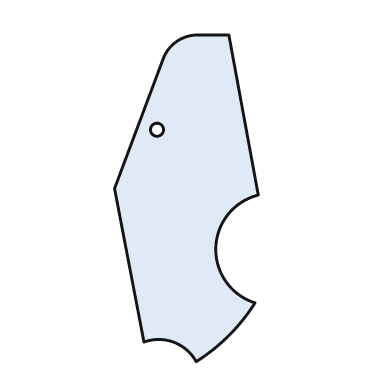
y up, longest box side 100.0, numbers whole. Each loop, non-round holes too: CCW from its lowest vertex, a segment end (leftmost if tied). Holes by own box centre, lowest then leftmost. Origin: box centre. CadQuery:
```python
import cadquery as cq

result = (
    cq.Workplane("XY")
    .moveTo(3.0, -50.0)
    .threePointArc((13.0, -42.0), (21.0, -32.0))
    .threePointArc((9.0, -15.0), (22.0, 1.0))
    .lineTo(13.0, 50.0)
    .lineTo(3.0, 50.0)
    .threePointArc((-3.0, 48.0), (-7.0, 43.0))
    .lineTo(-22.0, 3.0)
    .lineTo(-13.0, -44.0)
    .threePointArc((-4.0, -44.0), (3.0, -50.0))
    .close()
    .moveTo(-9.0, 21.0)
    .circle(2.0)
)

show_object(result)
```